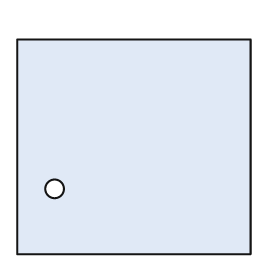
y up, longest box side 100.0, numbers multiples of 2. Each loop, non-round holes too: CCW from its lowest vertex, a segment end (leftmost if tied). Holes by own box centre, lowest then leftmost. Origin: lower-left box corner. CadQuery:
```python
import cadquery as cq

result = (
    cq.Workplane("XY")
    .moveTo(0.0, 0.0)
    .lineTo(100.0, 0.0)
    .lineTo(100.0, 92.0)
    .lineTo(0.0, 92.0)
    .close()
    .moveTo(16.0, 28.0)
    .circle(4.0)
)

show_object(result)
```